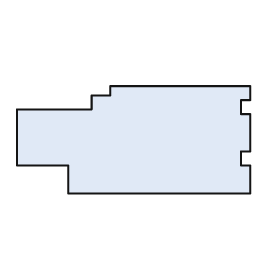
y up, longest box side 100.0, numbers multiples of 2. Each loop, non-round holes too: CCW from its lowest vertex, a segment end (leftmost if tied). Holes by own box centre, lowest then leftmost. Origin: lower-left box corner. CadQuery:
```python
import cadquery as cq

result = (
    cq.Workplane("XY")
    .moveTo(22.0, 0.0)
    .lineTo(100.0, 0.0)
    .lineTo(100.0, 12.0)
    .lineTo(96.0, 12.0)
    .lineTo(96.0, 18.0)
    .lineTo(100.0, 18.0)
    .lineTo(100.0, 34.0)
    .lineTo(96.0, 34.0)
    .lineTo(96.0, 40.0)
    .lineTo(100.0, 40.0)
    .lineTo(100.0, 46.0)
    .lineTo(40.0, 46.0)
    .lineTo(40.0, 42.0)
    .lineTo(32.0, 42.0)
    .lineTo(32.0, 36.0)
    .lineTo(0.0, 36.0)
    .lineTo(0.0, 12.0)
    .lineTo(22.0, 12.0)
    .close()
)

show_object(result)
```